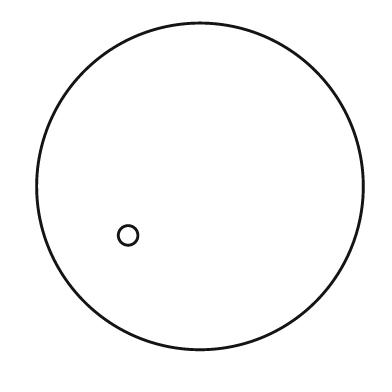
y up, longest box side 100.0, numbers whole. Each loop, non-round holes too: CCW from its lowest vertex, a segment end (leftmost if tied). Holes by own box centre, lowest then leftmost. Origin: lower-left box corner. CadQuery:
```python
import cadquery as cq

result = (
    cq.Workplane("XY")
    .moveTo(50.0, 50.0)
    .circle(50.0)
    .moveTo(28.0, 35.0)
    .circle(3.0)
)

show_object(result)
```